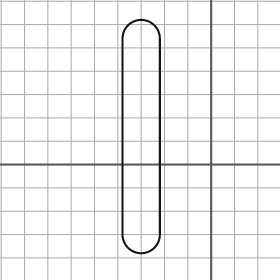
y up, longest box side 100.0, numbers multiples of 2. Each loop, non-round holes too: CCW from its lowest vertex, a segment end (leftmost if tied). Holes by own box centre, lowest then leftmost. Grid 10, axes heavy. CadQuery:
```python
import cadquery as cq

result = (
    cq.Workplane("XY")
    .moveTo(-38.0, -30.0)
    .threePointArc((-30.0, -38.0), (-22.0, -30.0))
    .lineTo(-22.0, 54.0)
    .threePointArc((-30.0, 62.0), (-38.0, 54.0))
    .close()
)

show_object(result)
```